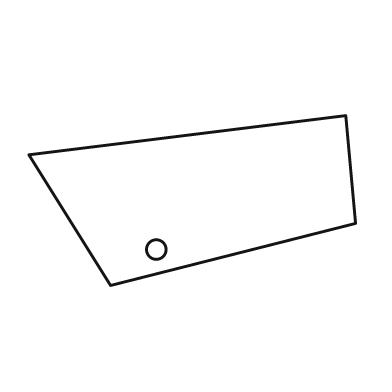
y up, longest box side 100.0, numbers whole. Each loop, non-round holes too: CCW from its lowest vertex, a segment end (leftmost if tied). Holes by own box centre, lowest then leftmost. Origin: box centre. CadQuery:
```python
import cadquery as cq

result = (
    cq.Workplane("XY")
    .moveTo(-25.0, -26.0)
    .lineTo(50.0, -7.0)
    .lineTo(47.0, 26.0)
    .lineTo(-50.0, 14.0)
    .close()
    .moveTo(-11.0, -15.0)
    .circle(3.0)
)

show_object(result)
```